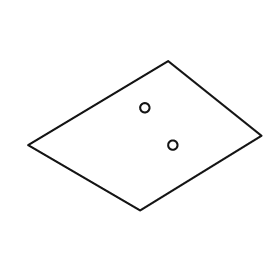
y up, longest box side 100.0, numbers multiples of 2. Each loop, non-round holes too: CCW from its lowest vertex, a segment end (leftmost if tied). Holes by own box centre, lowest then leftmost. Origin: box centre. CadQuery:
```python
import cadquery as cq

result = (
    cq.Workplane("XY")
    .moveTo(-2.0, -32.0)
    .lineTo(50.0, 0.0)
    .lineTo(10.0, 32.0)
    .lineTo(-50.0, -4.0)
    .close()
    .moveTo(12.0, -4.0)
    .circle(2.0)
    .moveTo(0.0, 12.0)
    .circle(2.0)
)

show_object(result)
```